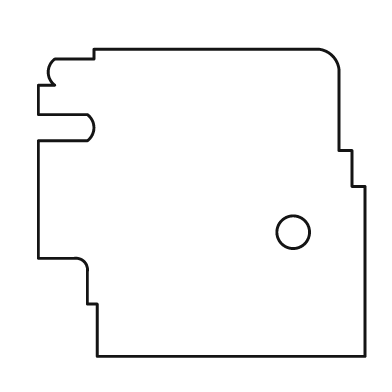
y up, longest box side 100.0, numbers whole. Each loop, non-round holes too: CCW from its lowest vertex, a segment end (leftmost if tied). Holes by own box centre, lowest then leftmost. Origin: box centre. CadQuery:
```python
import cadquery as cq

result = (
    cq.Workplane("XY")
    .moveTo(-32.0, -47.0)
    .lineTo(50.0, -47.0)
    .lineTo(50.0, 5.0)
    .lineTo(46.0, 5.0)
    .lineTo(46.0, 16.0)
    .lineTo(42.0, 16.0)
    .lineTo(42.0, 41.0)
    .threePointArc((40.0, 45.0), (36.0, 47.0))
    .lineTo(-33.0, 47.0)
    .lineTo(-33.0, 44.0)
    .lineTo(-45.0, 44.0)
    .threePointArc((-47.0, 40.0), (-45.0, 36.0))
    .lineTo(-50.0, 36.0)
    .lineTo(-50.0, 27.0)
    .lineTo(-35.0, 27.0)
    .threePointArc((-33.0, 23.0), (-35.0, 19.0))
    .lineTo(-50.0, 19.0)
    .lineTo(-50.0, -17.0)
    .lineTo(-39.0, -17.0)
    .threePointArc((-36.0, -18.0), (-35.0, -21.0))
    .lineTo(-35.0, -31.0)
    .lineTo(-32.0, -31.0)
    .close()
    .moveTo(28.0, -9.0)
    .circle(5.0)
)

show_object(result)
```